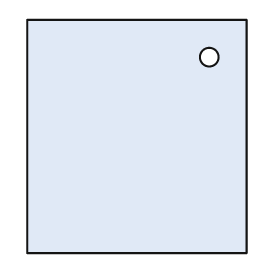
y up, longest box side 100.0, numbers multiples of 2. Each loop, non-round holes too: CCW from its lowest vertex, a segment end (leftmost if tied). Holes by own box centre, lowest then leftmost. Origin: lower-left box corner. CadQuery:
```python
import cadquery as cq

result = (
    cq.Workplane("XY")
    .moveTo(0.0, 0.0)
    .lineTo(94.0, 0.0)
    .lineTo(94.0, 100.0)
    .lineTo(0.0, 100.0)
    .close()
    .moveTo(78.0, 84.0)
    .circle(4.0)
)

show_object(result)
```